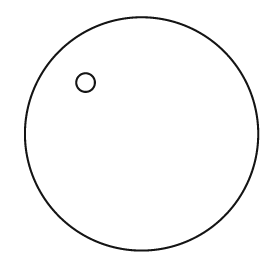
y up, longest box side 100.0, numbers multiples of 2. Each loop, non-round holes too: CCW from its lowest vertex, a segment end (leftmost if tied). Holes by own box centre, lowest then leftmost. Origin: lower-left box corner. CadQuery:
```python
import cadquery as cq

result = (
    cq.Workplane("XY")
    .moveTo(50.0, 50.0)
    .circle(50.0)
    .moveTo(26.0, 72.0)
    .circle(4.0)
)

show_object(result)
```